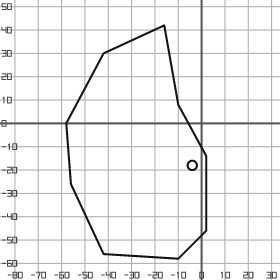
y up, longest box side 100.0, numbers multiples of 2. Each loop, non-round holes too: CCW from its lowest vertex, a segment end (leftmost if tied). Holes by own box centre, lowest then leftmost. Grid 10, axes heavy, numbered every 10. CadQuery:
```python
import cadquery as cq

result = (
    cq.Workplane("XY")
    .moveTo(-10.0, -58.0)
    .lineTo(2.0, -46.0)
    .lineTo(2.0, -14.0)
    .lineTo(-10.0, 8.0)
    .lineTo(-16.0, 42.0)
    .lineTo(-42.0, 30.0)
    .lineTo(-58.0, 0.0)
    .lineTo(-56.0, -26.0)
    .lineTo(-42.0, -56.0)
    .close()
    .moveTo(-4.0, -18.0)
    .circle(2.0)
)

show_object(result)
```